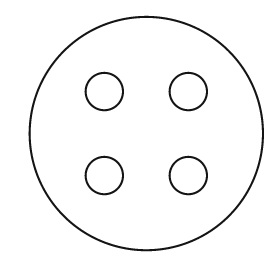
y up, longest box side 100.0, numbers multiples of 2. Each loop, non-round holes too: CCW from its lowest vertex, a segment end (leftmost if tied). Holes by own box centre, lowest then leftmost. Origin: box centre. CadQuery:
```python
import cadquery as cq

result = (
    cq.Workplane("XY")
    .moveTo(0.0, 0.0)
    .circle(50.0)
    .moveTo(-18.0, -18.0)
    .circle(8.0)
    .moveTo(18.0, -18.0)
    .circle(8.0)
    .moveTo(-18.0, 18.0)
    .circle(8.0)
    .moveTo(18.0, 18.0)
    .circle(8.0)
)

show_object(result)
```